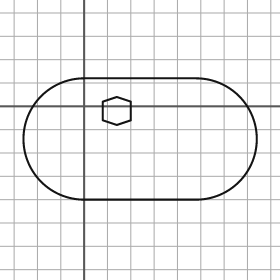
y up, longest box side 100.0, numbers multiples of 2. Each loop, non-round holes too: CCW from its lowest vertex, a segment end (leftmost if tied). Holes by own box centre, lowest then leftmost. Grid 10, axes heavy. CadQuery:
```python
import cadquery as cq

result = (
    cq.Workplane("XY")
    .moveTo(0.0, -40.0)
    .lineTo(48.0, -40.0)
    .threePointArc((74.0, -14.0), (48.0, 12.0))
    .lineTo(0.0, 12.0)
    .threePointArc((-26.0, -14.0), (0.0, -40.0))
    .close()
    .moveTo(14.0, -8.0)
    .lineTo(20.0, -6.0)
    .lineTo(20.0, 2.0)
    .lineTo(14.0, 4.0)
    .lineTo(8.0, 2.0)
    .lineTo(8.0, -6.0)
    .close()
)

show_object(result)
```